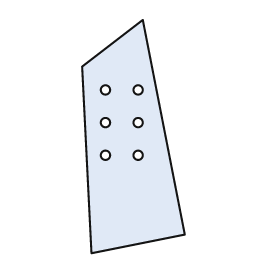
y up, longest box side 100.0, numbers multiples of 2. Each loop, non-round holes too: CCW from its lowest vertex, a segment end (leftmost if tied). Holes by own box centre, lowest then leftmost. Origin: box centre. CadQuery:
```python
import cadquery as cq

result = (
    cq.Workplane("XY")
    .moveTo(-18.0, -50.0)
    .lineTo(22.0, -42.0)
    .lineTo(4.0, 50.0)
    .lineTo(-22.0, 30.0)
    .close()
    .moveTo(-12.0, -8.0)
    .circle(2.0)
    .moveTo(2.0, -8.0)
    .circle(2.0)
    .moveTo(-12.0, 6.0)
    .circle(2.0)
    .moveTo(2.0, 6.0)
    .circle(2.0)
    .moveTo(-12.0, 20.0)
    .circle(2.0)
    .moveTo(2.0, 20.0)
    .circle(2.0)
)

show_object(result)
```